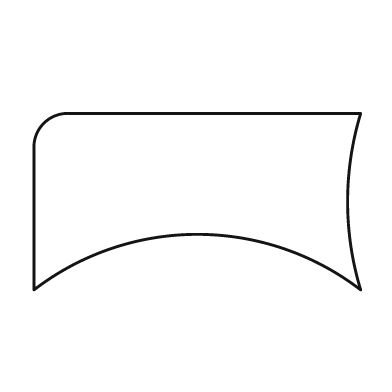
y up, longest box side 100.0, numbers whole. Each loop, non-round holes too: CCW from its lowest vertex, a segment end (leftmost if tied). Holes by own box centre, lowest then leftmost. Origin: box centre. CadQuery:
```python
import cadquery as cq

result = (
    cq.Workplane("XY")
    .moveTo(-50.0, -27.0)
    .threePointArc((0.0, -10.0), (50.0, -27.0))
    .threePointArc((46.0, 0.0), (50.0, 27.0))
    .lineTo(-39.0, 27.0)
    .threePointArc((-47.0, 24.0), (-50.0, 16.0))
    .close()
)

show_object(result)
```